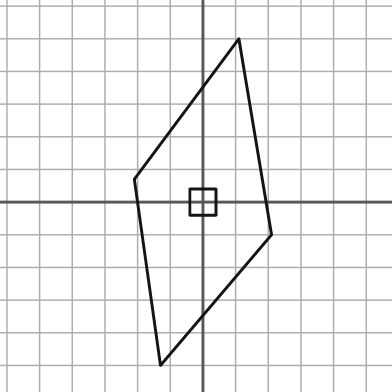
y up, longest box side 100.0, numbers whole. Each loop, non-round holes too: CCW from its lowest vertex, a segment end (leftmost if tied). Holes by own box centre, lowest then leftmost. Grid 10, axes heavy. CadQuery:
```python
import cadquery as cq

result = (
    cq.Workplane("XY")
    .moveTo(-13.0, -50.0)
    .lineTo(21.0, -10.0)
    .lineTo(11.0, 50.0)
    .lineTo(-21.0, 7.0)
    .close()
    .moveTo(-4.0, -4.0)
    .lineTo(4.0, -4.0)
    .lineTo(4.0, 4.0)
    .lineTo(-4.0, 4.0)
    .close()
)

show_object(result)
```